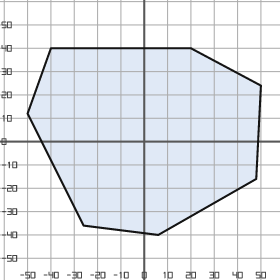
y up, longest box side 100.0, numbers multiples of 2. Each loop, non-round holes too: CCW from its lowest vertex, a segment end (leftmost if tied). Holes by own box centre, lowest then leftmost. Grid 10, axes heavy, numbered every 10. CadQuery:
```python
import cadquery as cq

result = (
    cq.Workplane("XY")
    .moveTo(6.0, -40.0)
    .lineTo(48.0, -16.0)
    .lineTo(50.0, 24.0)
    .lineTo(20.0, 40.0)
    .lineTo(-40.0, 40.0)
    .lineTo(-50.0, 12.0)
    .lineTo(-26.0, -36.0)
    .close()
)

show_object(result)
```